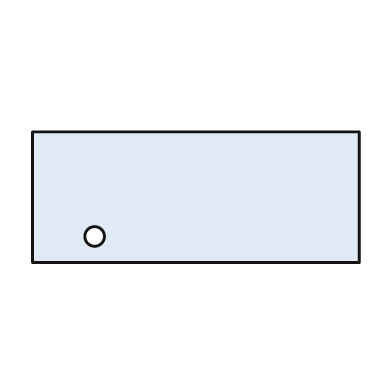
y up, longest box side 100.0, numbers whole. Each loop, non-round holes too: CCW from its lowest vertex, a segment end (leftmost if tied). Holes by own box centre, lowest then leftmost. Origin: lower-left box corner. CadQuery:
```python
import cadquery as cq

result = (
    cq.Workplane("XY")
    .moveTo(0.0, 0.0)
    .lineTo(100.0, 0.0)
    .lineTo(100.0, 40.0)
    .lineTo(0.0, 40.0)
    .close()
    .moveTo(19.0, 8.0)
    .circle(3.0)
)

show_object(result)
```